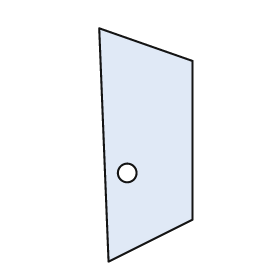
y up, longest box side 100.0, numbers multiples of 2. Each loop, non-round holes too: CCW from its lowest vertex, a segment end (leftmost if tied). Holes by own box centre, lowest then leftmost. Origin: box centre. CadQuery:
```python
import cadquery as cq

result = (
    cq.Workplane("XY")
    .moveTo(-16.0, -50.0)
    .lineTo(20.0, -32.0)
    .lineTo(20.0, 36.0)
    .lineTo(-20.0, 50.0)
    .close()
    .moveTo(-8.0, -12.0)
    .circle(4.0)
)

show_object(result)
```